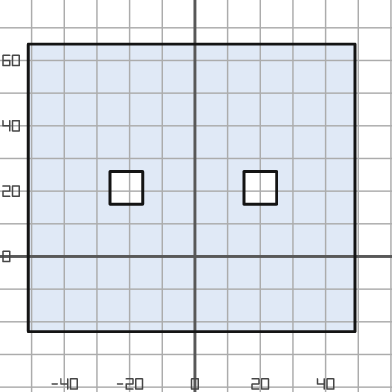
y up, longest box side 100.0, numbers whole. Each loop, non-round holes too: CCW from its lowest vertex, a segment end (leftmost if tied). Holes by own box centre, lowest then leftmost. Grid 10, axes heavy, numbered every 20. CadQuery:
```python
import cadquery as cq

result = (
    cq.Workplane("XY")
    .moveTo(-51.0, -23.0)
    .lineTo(49.0, -23.0)
    .lineTo(49.0, 65.0)
    .lineTo(-51.0, 65.0)
    .close()
    .moveTo(-26.0, 16.0)
    .lineTo(-16.0, 16.0)
    .lineTo(-16.0, 26.0)
    .lineTo(-26.0, 26.0)
    .close()
    .moveTo(15.0, 16.0)
    .lineTo(25.0, 16.0)
    .lineTo(25.0, 26.0)
    .lineTo(15.0, 26.0)
    .close()
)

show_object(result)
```